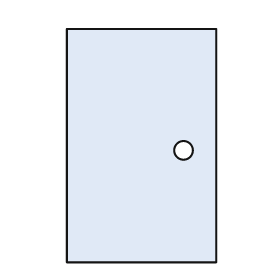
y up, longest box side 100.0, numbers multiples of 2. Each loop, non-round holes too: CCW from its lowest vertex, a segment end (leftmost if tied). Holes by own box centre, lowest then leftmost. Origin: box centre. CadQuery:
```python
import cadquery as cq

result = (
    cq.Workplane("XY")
    .moveTo(-32.0, -50.0)
    .lineTo(32.0, -50.0)
    .lineTo(32.0, 50.0)
    .lineTo(-32.0, 50.0)
    .close()
    .moveTo(18.0, -2.0)
    .circle(4.0)
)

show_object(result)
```